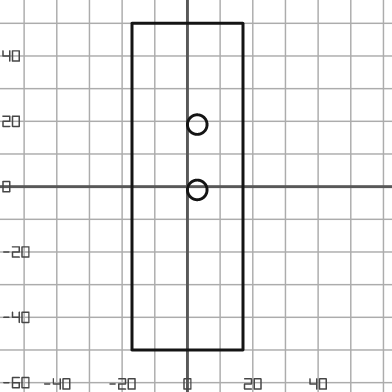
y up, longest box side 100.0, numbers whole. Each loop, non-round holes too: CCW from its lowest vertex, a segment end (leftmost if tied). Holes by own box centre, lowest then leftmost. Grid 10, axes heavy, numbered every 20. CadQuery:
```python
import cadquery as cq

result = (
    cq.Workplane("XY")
    .moveTo(-17.0, -50.0)
    .lineTo(17.0, -50.0)
    .lineTo(17.0, 50.0)
    .lineTo(-17.0, 50.0)
    .close()
    .moveTo(3.0, -1.0)
    .circle(3.0)
    .moveTo(3.0, 19.0)
    .circle(3.0)
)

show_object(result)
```